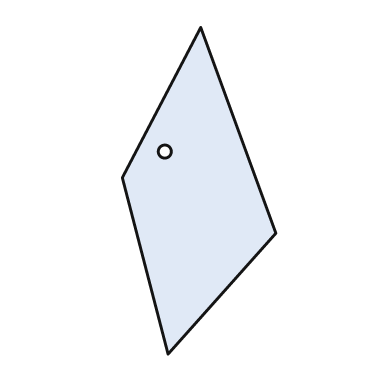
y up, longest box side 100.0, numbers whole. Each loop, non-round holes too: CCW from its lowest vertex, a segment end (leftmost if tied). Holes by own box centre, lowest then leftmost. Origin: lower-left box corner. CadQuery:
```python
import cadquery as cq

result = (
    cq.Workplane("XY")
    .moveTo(14.0, 0.0)
    .lineTo(47.0, 37.0)
    .lineTo(24.0, 100.0)
    .lineTo(0.0, 54.0)
    .close()
    .moveTo(13.0, 62.0)
    .circle(2.0)
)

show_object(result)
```